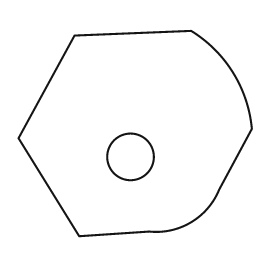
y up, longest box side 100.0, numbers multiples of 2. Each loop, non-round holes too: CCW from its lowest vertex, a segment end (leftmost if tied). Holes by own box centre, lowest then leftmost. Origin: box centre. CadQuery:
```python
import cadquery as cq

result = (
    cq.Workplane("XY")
    .moveTo(-24.0, -44.0)
    .lineTo(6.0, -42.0)
    .threePointArc((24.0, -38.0), (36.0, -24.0))
    .lineTo(50.0, 2.0)
    .threePointArc((42.0, 26.0), (24.0, 44.0))
    .lineTo(-26.0, 42.0)
    .lineTo(-50.0, -2.0)
    .close()
    .moveTo(-2.0, -10.0)
    .circle(10.0)
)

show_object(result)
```